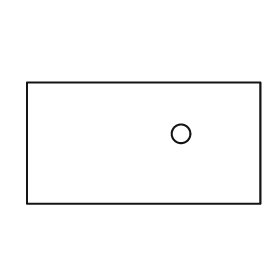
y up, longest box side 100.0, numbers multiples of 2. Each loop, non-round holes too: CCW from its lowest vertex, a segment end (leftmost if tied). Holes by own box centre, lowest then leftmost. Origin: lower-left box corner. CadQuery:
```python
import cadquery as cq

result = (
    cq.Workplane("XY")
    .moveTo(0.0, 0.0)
    .lineTo(100.0, 0.0)
    .lineTo(100.0, 52.0)
    .lineTo(0.0, 52.0)
    .close()
    .moveTo(66.0, 30.0)
    .circle(4.0)
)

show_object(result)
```